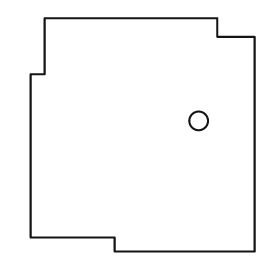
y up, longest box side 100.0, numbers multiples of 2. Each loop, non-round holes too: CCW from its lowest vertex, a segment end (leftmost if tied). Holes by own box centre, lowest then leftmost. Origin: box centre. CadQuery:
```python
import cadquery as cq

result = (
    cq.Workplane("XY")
    .moveTo(-12.0, -50.0)
    .lineTo(48.0, -50.0)
    .lineTo(48.0, 42.0)
    .lineTo(32.0, 42.0)
    .lineTo(32.0, 50.0)
    .lineTo(-42.0, 50.0)
    .lineTo(-42.0, 26.0)
    .lineTo(-48.0, 26.0)
    .lineTo(-48.0, -44.0)
    .lineTo(-12.0, -44.0)
    .close()
    .moveTo(24.0, 6.0)
    .circle(4.0)
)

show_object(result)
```